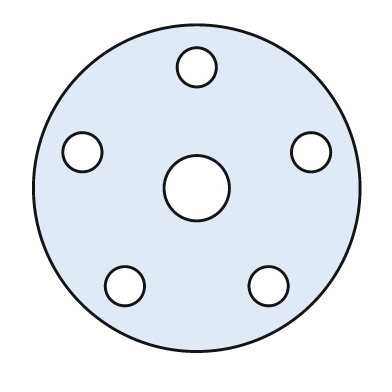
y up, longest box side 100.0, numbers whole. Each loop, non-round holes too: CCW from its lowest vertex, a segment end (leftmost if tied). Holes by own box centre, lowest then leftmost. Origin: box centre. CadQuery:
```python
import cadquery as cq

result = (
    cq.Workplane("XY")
    .moveTo(0.0, 0.0)
    .circle(50.0)
    .moveTo(-22.0, -30.0)
    .circle(6.0)
    .moveTo(22.0, -30.0)
    .circle(6.0)
    .moveTo(0.0, 0.0)
    .circle(10.0)
    .moveTo(-35.0, 11.0)
    .circle(6.0)
    .moveTo(35.0, 11.0)
    .circle(6.0)
    .moveTo(0.0, 37.0)
    .circle(6.0)
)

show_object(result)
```